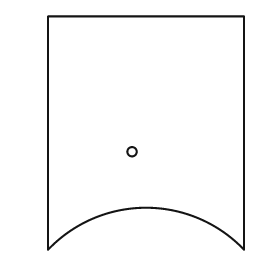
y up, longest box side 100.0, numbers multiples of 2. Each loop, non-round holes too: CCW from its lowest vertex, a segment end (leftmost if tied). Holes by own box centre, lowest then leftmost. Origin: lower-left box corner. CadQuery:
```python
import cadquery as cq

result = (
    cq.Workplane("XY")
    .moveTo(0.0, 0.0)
    .threePointArc((42.0, 18.0), (84.0, 0.0))
    .lineTo(84.0, 100.0)
    .lineTo(0.0, 100.0)
    .close()
    .moveTo(36.0, 42.0)
    .circle(2.0)
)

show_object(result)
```